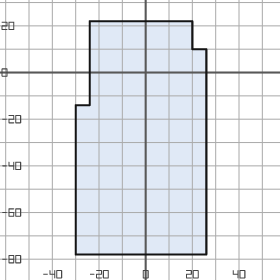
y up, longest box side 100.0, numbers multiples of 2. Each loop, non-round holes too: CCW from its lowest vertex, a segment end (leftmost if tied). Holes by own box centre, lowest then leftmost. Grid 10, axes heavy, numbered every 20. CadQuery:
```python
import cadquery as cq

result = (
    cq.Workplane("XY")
    .moveTo(-30.0, -78.0)
    .lineTo(26.0, -78.0)
    .lineTo(26.0, 10.0)
    .lineTo(20.0, 10.0)
    .lineTo(20.0, 22.0)
    .lineTo(-24.0, 22.0)
    .lineTo(-24.0, -14.0)
    .lineTo(-30.0, -14.0)
    .close()
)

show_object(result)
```